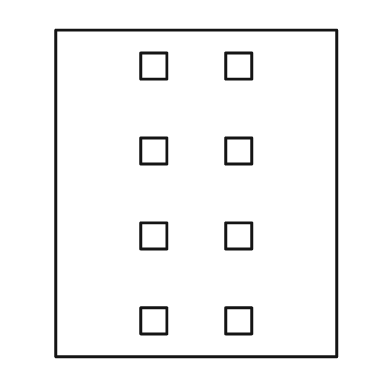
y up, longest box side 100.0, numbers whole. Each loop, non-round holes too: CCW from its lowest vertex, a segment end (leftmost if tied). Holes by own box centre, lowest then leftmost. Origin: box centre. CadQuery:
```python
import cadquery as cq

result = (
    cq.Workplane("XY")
    .moveTo(-43.0, -50.0)
    .lineTo(43.0, -50.0)
    .lineTo(43.0, 50.0)
    .lineTo(-43.0, 50.0)
    .close()
    .moveTo(-17.0, -43.0)
    .lineTo(-9.0, -43.0)
    .lineTo(-9.0, -35.0)
    .lineTo(-17.0, -35.0)
    .close()
    .moveTo(9.0, -43.0)
    .lineTo(17.0, -43.0)
    .lineTo(17.0, -35.0)
    .lineTo(9.0, -35.0)
    .close()
    .moveTo(-17.0, -17.0)
    .lineTo(-9.0, -17.0)
    .lineTo(-9.0, -9.0)
    .lineTo(-17.0, -9.0)
    .close()
    .moveTo(9.0, -17.0)
    .lineTo(17.0, -17.0)
    .lineTo(17.0, -9.0)
    .lineTo(9.0, -9.0)
    .close()
    .moveTo(-17.0, 9.0)
    .lineTo(-9.0, 9.0)
    .lineTo(-9.0, 17.0)
    .lineTo(-17.0, 17.0)
    .close()
    .moveTo(9.0, 9.0)
    .lineTo(17.0, 9.0)
    .lineTo(17.0, 17.0)
    .lineTo(9.0, 17.0)
    .close()
    .moveTo(-17.0, 35.0)
    .lineTo(-9.0, 35.0)
    .lineTo(-9.0, 43.0)
    .lineTo(-17.0, 43.0)
    .close()
    .moveTo(9.0, 35.0)
    .lineTo(17.0, 35.0)
    .lineTo(17.0, 43.0)
    .lineTo(9.0, 43.0)
    .close()
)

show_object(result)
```